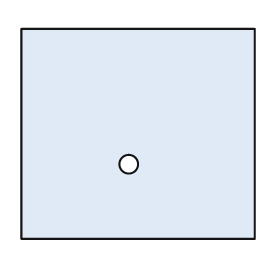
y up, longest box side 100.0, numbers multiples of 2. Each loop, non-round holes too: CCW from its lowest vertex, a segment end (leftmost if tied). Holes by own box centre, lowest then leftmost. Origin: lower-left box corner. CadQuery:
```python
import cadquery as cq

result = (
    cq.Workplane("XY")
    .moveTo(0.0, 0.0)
    .lineTo(100.0, 0.0)
    .lineTo(100.0, 90.0)
    .lineTo(0.0, 90.0)
    .close()
    .moveTo(46.0, 32.0)
    .circle(4.0)
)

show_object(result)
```